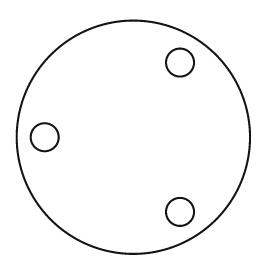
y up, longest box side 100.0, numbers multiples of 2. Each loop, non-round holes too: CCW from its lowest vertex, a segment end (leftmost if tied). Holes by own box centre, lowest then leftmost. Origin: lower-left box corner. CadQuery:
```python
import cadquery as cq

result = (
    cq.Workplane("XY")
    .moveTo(50.0, 50.0)
    .circle(50.0)
    .moveTo(70.0, 18.0)
    .circle(6.0)
    .moveTo(12.0, 50.0)
    .circle(6.0)
    .moveTo(70.0, 82.0)
    .circle(6.0)
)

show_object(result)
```